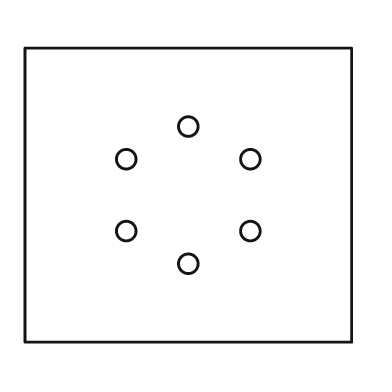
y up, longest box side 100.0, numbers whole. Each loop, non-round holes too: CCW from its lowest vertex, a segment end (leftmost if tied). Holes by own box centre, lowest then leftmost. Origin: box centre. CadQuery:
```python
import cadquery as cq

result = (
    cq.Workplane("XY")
    .moveTo(-50.0, -45.0)
    .lineTo(50.0, -45.0)
    .lineTo(50.0, 45.0)
    .lineTo(-50.0, 45.0)
    .close()
    .moveTo(0.0, -21.0)
    .circle(3.0)
    .moveTo(-19.0, -11.0)
    .circle(3.0)
    .moveTo(19.0, -11.0)
    .circle(3.0)
    .moveTo(-19.0, 11.0)
    .circle(3.0)
    .moveTo(19.0, 11.0)
    .circle(3.0)
    .moveTo(0.0, 21.0)
    .circle(3.0)
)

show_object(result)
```